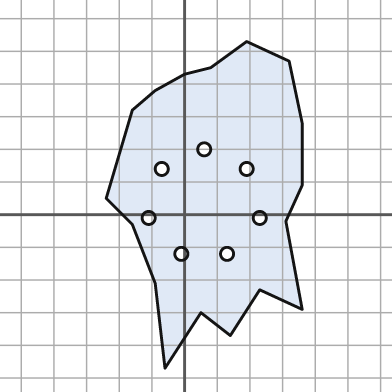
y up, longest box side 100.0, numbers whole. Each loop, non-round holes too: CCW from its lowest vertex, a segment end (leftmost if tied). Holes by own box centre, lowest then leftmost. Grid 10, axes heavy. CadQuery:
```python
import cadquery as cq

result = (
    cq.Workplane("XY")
    .moveTo(-6.0, -47.0)
    .lineTo(5.0, -30.0)
    .lineTo(14.0, -37.0)
    .lineTo(23.0, -23.0)
    .lineTo(36.0, -29.0)
    .lineTo(31.0, -2.0)
    .lineTo(36.0, 9.0)
    .lineTo(36.0, 28.0)
    .lineTo(32.0, 47.0)
    .lineTo(19.0, 53.0)
    .lineTo(8.0, 45.0)
    .lineTo(0.0, 43.0)
    .lineTo(-9.0, 38.0)
    .lineTo(-16.0, 32.0)
    .lineTo(-24.0, 5.0)
    .lineTo(-16.0, -3.0)
    .lineTo(-9.0, -21.0)
    .close()
    .moveTo(-1.0, -12.0)
    .circle(2.0)
    .moveTo(13.0, -12.0)
    .circle(2.0)
    .moveTo(-11.0, -1.0)
    .circle(2.0)
    .moveTo(23.0, -1.0)
    .circle(2.0)
    .moveTo(-7.0, 14.0)
    .circle(2.0)
    .moveTo(19.0, 14.0)
    .circle(2.0)
    .moveTo(6.0, 20.0)
    .circle(2.0)
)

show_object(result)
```